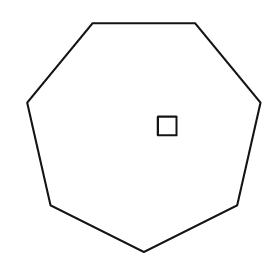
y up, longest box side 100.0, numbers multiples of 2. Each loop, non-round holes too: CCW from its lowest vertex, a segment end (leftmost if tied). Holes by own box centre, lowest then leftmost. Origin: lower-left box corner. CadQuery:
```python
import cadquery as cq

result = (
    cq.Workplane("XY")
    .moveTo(50.0, 0.0)
    .lineTo(90.0, 20.0)
    .lineTo(100.0, 64.0)
    .lineTo(72.0, 98.0)
    .lineTo(28.0, 98.0)
    .lineTo(0.0, 64.0)
    .lineTo(10.0, 20.0)
    .close()
    .moveTo(56.0, 50.0)
    .lineTo(64.0, 50.0)
    .lineTo(64.0, 58.0)
    .lineTo(56.0, 58.0)
    .close()
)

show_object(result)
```